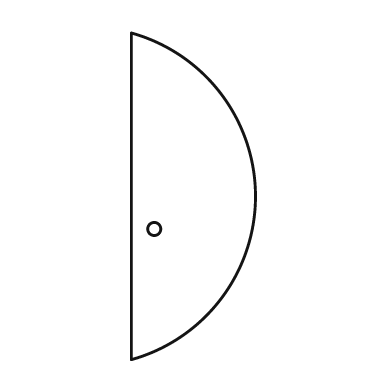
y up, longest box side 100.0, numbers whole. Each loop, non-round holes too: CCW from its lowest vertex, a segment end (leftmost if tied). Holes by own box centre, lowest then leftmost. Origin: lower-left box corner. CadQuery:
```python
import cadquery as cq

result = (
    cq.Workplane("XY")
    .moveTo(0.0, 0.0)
    .threePointArc((38.0, 50.0), (0.0, 100.0))
    .close()
    .moveTo(7.0, 40.0)
    .circle(2.0)
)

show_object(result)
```